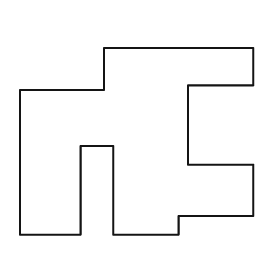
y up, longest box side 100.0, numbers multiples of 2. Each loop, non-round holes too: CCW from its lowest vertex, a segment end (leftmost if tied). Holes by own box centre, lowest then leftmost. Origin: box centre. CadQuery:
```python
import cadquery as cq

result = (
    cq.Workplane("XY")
    .moveTo(-50.0, -40.0)
    .lineTo(-24.0, -40.0)
    .lineTo(-24.0, -2.0)
    .lineTo(-10.0, -2.0)
    .lineTo(-10.0, -40.0)
    .lineTo(18.0, -40.0)
    .lineTo(18.0, -32.0)
    .lineTo(50.0, -32.0)
    .lineTo(50.0, -10.0)
    .lineTo(22.0, -10.0)
    .lineTo(22.0, 24.0)
    .lineTo(50.0, 24.0)
    .lineTo(50.0, 40.0)
    .lineTo(-14.0, 40.0)
    .lineTo(-14.0, 22.0)
    .lineTo(-50.0, 22.0)
    .close()
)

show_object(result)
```